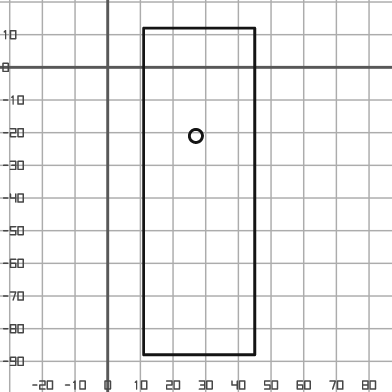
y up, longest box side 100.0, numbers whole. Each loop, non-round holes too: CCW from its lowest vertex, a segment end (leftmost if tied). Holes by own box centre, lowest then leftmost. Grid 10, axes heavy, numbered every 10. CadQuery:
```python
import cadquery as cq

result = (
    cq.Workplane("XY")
    .moveTo(11.0, -88.0)
    .lineTo(45.0, -88.0)
    .lineTo(45.0, 12.0)
    .lineTo(11.0, 12.0)
    .close()
    .moveTo(27.0, -21.0)
    .circle(2.0)
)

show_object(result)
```